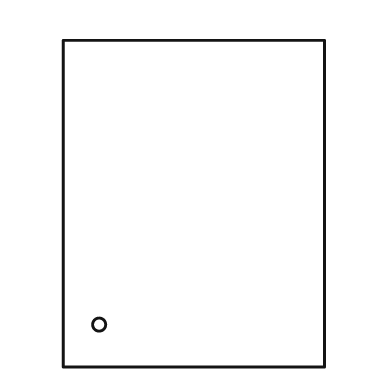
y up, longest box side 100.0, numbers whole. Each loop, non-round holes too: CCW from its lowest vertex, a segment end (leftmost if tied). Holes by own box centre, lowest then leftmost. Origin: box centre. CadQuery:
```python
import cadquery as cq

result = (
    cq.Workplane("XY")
    .moveTo(-40.0, -50.0)
    .lineTo(40.0, -50.0)
    .lineTo(40.0, 50.0)
    .lineTo(-40.0, 50.0)
    .close()
    .moveTo(-29.0, -37.0)
    .circle(2.0)
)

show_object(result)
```